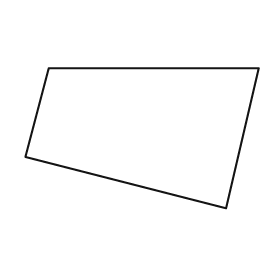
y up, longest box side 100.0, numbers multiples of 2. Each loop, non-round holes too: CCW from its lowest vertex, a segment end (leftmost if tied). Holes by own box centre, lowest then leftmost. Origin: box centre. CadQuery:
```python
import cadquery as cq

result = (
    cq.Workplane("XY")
    .moveTo(36.0, -30.0)
    .lineTo(50.0, 30.0)
    .lineTo(-40.0, 30.0)
    .lineTo(-50.0, -8.0)
    .close()
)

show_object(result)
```